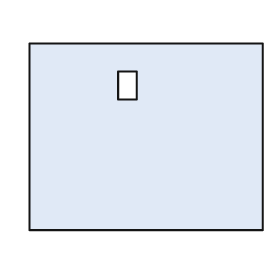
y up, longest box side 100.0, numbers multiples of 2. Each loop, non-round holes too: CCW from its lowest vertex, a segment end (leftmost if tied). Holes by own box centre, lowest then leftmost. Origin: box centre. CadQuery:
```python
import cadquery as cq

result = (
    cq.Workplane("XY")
    .moveTo(-50.0, -40.0)
    .lineTo(50.0, -40.0)
    .lineTo(50.0, 40.0)
    .lineTo(-50.0, 40.0)
    .close()
    .moveTo(-12.0, 16.0)
    .lineTo(-4.0, 16.0)
    .lineTo(-4.0, 28.0)
    .lineTo(-12.0, 28.0)
    .close()
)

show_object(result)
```